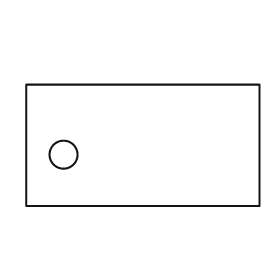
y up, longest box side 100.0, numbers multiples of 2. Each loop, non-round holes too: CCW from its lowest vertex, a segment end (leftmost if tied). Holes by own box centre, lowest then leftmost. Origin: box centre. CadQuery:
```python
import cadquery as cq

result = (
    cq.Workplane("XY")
    .moveTo(-50.0, -26.0)
    .lineTo(50.0, -26.0)
    .lineTo(50.0, 26.0)
    .lineTo(-50.0, 26.0)
    .close()
    .moveTo(-34.0, -4.0)
    .circle(6.0)
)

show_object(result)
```